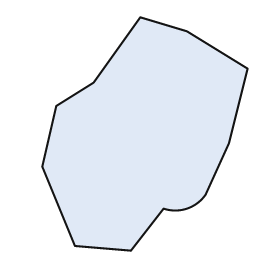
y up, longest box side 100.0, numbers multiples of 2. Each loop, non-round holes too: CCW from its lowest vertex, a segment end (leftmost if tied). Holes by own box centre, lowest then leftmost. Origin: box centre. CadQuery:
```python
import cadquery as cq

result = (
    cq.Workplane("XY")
    .moveTo(-6.0, -50.0)
    .lineTo(8.0, -32.0)
    .threePointArc((18.0, -32.0), (26.0, -26.0))
    .lineTo(36.0, -4.0)
    .lineTo(44.0, 28.0)
    .lineTo(18.0, 44.0)
    .lineTo(-2.0, 50.0)
    .lineTo(-22.0, 22.0)
    .lineTo(-38.0, 12.0)
    .lineTo(-44.0, -14.0)
    .lineTo(-30.0, -48.0)
    .close()
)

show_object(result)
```